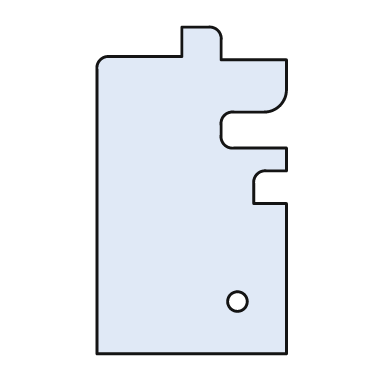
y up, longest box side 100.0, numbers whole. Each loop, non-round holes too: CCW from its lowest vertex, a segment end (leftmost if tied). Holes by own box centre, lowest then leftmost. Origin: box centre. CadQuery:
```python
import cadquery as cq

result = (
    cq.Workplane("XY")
    .moveTo(-29.0, -50.0)
    .lineTo(29.0, -50.0)
    .lineTo(29.0, -4.0)
    .lineTo(19.0, -4.0)
    .lineTo(19.0, 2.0)
    .threePointArc((20.0, 5.0), (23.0, 6.0))
    .lineTo(29.0, 6.0)
    .lineTo(29.0, 13.0)
    .lineTo(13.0, 13.0)
    .threePointArc((10.0, 14.0), (9.0, 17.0))
    .lineTo(9.0, 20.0)
    .threePointArc((10.0, 23.0), (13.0, 24.0))
    .lineTo(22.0, 24.0)
    .threePointArc((27.0, 26.0), (29.0, 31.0))
    .lineTo(29.0, 40.0)
    .lineTo(9.0, 40.0)
    .lineTo(9.0, 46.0)
    .threePointArc((8.0, 49.0), (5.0, 50.0))
    .lineTo(-3.0, 50.0)
    .lineTo(-3.0, 41.0)
    .lineTo(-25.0, 41.0)
    .threePointArc((-28.0, 40.0), (-29.0, 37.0))
    .close()
    .moveTo(14.0, -34.0)
    .circle(3.0)
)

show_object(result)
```